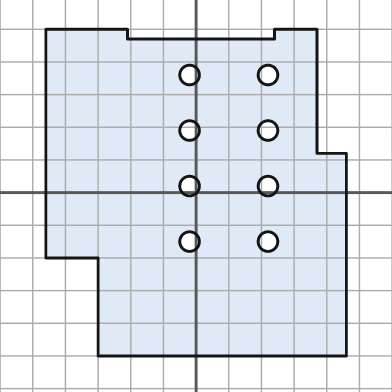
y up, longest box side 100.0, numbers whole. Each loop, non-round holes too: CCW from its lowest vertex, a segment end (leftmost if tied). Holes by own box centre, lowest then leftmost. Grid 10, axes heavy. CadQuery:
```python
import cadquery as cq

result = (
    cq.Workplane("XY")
    .moveTo(-30.0, -50.0)
    .lineTo(46.0, -50.0)
    .lineTo(46.0, 12.0)
    .lineTo(37.0, 12.0)
    .lineTo(37.0, 50.0)
    .lineTo(24.0, 50.0)
    .lineTo(24.0, 47.0)
    .lineTo(-21.0, 47.0)
    .lineTo(-21.0, 50.0)
    .lineTo(-46.0, 50.0)
    .lineTo(-46.0, -20.0)
    .lineTo(-30.0, -20.0)
    .close()
    .moveTo(-2.0, -15.0)
    .circle(3.0)
    .moveTo(22.0, -15.0)
    .circle(3.0)
    .moveTo(-2.0, 2.0)
    .circle(3.0)
    .moveTo(22.0, 2.0)
    .circle(3.0)
    .moveTo(-2.0, 19.0)
    .circle(3.0)
    .moveTo(22.0, 19.0)
    .circle(3.0)
    .moveTo(-2.0, 36.0)
    .circle(3.0)
    .moveTo(22.0, 36.0)
    .circle(3.0)
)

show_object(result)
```